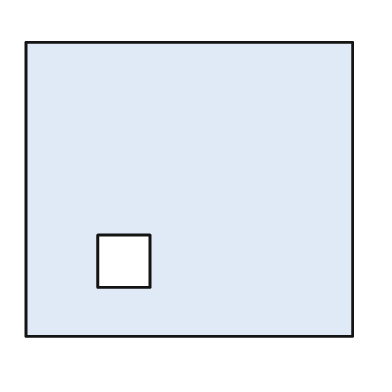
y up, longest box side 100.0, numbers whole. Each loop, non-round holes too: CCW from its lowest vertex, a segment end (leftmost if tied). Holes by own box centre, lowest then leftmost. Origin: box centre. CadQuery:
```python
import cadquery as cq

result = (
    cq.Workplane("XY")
    .moveTo(-50.0, -45.0)
    .lineTo(50.0, -45.0)
    .lineTo(50.0, 45.0)
    .lineTo(-50.0, 45.0)
    .close()
    .moveTo(-28.0, -30.0)
    .lineTo(-12.0, -30.0)
    .lineTo(-12.0, -14.0)
    .lineTo(-28.0, -14.0)
    .close()
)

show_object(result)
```